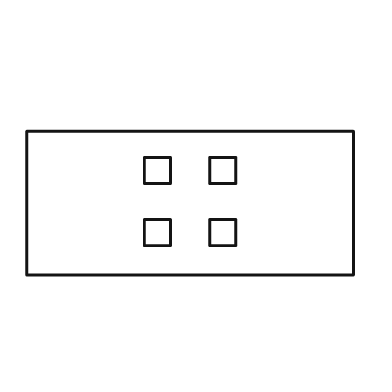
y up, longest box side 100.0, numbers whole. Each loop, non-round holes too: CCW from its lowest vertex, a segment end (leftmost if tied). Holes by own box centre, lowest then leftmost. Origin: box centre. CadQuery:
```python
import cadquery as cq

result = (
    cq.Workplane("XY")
    .moveTo(-50.0, -22.0)
    .lineTo(50.0, -22.0)
    .lineTo(50.0, 22.0)
    .lineTo(-50.0, 22.0)
    .close()
    .moveTo(-14.0, -13.0)
    .lineTo(-6.0, -13.0)
    .lineTo(-6.0, -5.0)
    .lineTo(-14.0, -5.0)
    .close()
    .moveTo(6.0, -13.0)
    .lineTo(14.0, -13.0)
    .lineTo(14.0, -5.0)
    .lineTo(6.0, -5.0)
    .close()
    .moveTo(-14.0, 6.0)
    .lineTo(-6.0, 6.0)
    .lineTo(-6.0, 14.0)
    .lineTo(-14.0, 14.0)
    .close()
    .moveTo(6.0, 6.0)
    .lineTo(14.0, 6.0)
    .lineTo(14.0, 14.0)
    .lineTo(6.0, 14.0)
    .close()
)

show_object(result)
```